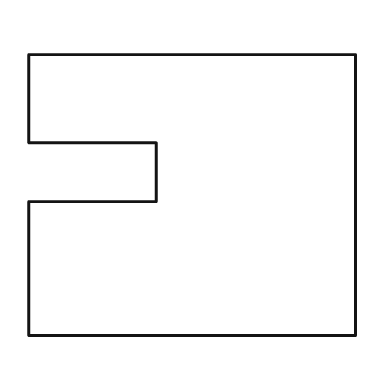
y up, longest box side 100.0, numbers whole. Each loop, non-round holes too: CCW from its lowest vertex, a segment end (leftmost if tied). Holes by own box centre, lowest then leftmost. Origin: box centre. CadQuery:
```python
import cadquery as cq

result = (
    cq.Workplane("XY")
    .moveTo(-50.0, -43.0)
    .lineTo(50.0, -43.0)
    .lineTo(50.0, 43.0)
    .lineTo(-50.0, 43.0)
    .lineTo(-50.0, 16.0)
    .lineTo(-11.0, 16.0)
    .lineTo(-11.0, -2.0)
    .lineTo(-50.0, -2.0)
    .close()
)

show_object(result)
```